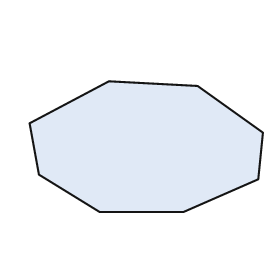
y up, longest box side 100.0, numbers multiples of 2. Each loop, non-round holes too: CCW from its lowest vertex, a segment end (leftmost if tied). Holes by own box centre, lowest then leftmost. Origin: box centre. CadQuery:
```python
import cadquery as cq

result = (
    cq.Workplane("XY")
    .moveTo(-20.0, -28.0)
    .lineTo(16.0, -28.0)
    .lineTo(48.0, -14.0)
    .lineTo(50.0, 6.0)
    .lineTo(22.0, 26.0)
    .lineTo(-16.0, 28.0)
    .lineTo(-50.0, 10.0)
    .lineTo(-46.0, -12.0)
    .close()
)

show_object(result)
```